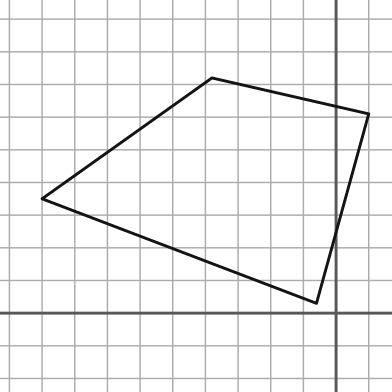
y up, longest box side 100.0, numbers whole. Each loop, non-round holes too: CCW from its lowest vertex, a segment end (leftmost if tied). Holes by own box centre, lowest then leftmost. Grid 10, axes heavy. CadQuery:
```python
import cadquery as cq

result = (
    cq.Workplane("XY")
    .moveTo(-6.0, 3.0)
    .lineTo(10.0, 61.0)
    .lineTo(-38.0, 72.0)
    .lineTo(-90.0, 35.0)
    .close()
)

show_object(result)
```